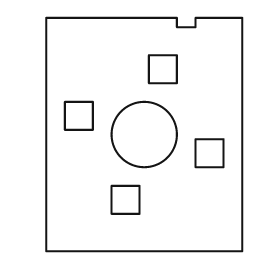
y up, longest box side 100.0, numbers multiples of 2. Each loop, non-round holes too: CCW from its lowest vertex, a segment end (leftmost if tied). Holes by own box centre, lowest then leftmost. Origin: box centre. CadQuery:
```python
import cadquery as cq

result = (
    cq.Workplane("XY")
    .moveTo(-42.0, -50.0)
    .lineTo(42.0, -50.0)
    .lineTo(42.0, 50.0)
    .lineTo(22.0, 50.0)
    .lineTo(22.0, 46.0)
    .lineTo(14.0, 46.0)
    .lineTo(14.0, 50.0)
    .lineTo(-42.0, 50.0)
    .close()
    .moveTo(-14.0, -34.0)
    .lineTo(-2.0, -34.0)
    .lineTo(-2.0, -22.0)
    .lineTo(-14.0, -22.0)
    .close()
    .moveTo(22.0, -14.0)
    .lineTo(34.0, -14.0)
    .lineTo(34.0, -2.0)
    .lineTo(22.0, -2.0)
    .close()
    .moveTo(0.0, 0.0)
    .circle(14.0)
    .moveTo(-34.0, 2.0)
    .lineTo(-22.0, 2.0)
    .lineTo(-22.0, 14.0)
    .lineTo(-34.0, 14.0)
    .close()
    .moveTo(2.0, 22.0)
    .lineTo(14.0, 22.0)
    .lineTo(14.0, 34.0)
    .lineTo(2.0, 34.0)
    .close()
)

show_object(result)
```